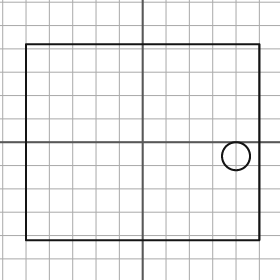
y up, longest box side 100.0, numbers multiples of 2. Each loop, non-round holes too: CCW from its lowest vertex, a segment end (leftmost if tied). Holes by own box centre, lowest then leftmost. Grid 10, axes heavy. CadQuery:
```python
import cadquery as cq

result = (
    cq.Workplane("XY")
    .moveTo(-50.0, -42.0)
    .lineTo(50.0, -42.0)
    .lineTo(50.0, 42.0)
    .lineTo(-50.0, 42.0)
    .close()
    .moveTo(40.0, -6.0)
    .circle(6.0)
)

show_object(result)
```